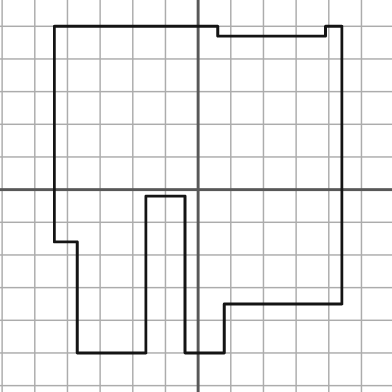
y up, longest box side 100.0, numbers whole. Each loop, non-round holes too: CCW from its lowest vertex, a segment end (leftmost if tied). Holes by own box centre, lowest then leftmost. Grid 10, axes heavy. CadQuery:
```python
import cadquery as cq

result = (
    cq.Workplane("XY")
    .moveTo(-37.0, -50.0)
    .lineTo(-16.0, -50.0)
    .lineTo(-16.0, -2.0)
    .lineTo(-4.0, -2.0)
    .lineTo(-4.0, -50.0)
    .lineTo(8.0, -50.0)
    .lineTo(8.0, -35.0)
    .lineTo(44.0, -35.0)
    .lineTo(44.0, 50.0)
    .lineTo(39.0, 50.0)
    .lineTo(39.0, 47.0)
    .lineTo(6.0, 47.0)
    .lineTo(6.0, 50.0)
    .lineTo(-44.0, 50.0)
    .lineTo(-44.0, -16.0)
    .lineTo(-37.0, -16.0)
    .close()
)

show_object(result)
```